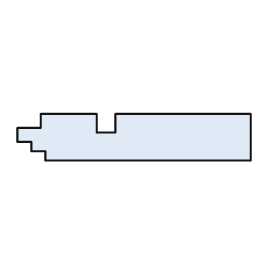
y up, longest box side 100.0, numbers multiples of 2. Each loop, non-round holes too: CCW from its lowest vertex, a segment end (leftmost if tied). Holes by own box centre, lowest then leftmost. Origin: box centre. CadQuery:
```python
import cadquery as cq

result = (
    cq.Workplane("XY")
    .moveTo(-38.0, -10.0)
    .lineTo(50.0, -10.0)
    .lineTo(50.0, 10.0)
    .lineTo(-8.0, 10.0)
    .lineTo(-8.0, 2.0)
    .lineTo(-16.0, 2.0)
    .lineTo(-16.0, 10.0)
    .lineTo(-40.0, 10.0)
    .lineTo(-40.0, 4.0)
    .lineTo(-50.0, 4.0)
    .lineTo(-50.0, -2.0)
    .lineTo(-44.0, -2.0)
    .lineTo(-44.0, -6.0)
    .lineTo(-38.0, -6.0)
    .close()
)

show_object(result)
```